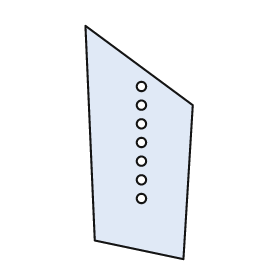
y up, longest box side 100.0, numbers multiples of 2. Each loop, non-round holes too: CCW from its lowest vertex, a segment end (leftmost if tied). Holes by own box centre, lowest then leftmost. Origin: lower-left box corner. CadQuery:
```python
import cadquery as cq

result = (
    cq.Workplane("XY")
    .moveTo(42.0, 0.0)
    .lineTo(46.0, 66.0)
    .lineTo(0.0, 100.0)
    .lineTo(4.0, 8.0)
    .close()
    .moveTo(24.0, 26.0)
    .circle(2.0)
    .moveTo(24.0, 34.0)
    .circle(2.0)
    .moveTo(24.0, 42.0)
    .circle(2.0)
    .moveTo(24.0, 50.0)
    .circle(2.0)
    .moveTo(24.0, 58.0)
    .circle(2.0)
    .moveTo(24.0, 66.0)
    .circle(2.0)
    .moveTo(24.0, 74.0)
    .circle(2.0)
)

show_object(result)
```